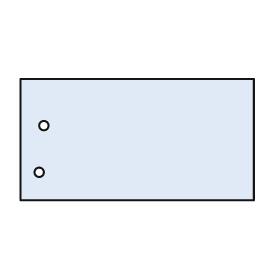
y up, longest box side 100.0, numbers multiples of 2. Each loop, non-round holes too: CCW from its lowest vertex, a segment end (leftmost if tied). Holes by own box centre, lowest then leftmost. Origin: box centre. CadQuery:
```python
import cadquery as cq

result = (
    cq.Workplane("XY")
    .moveTo(-50.0, -26.0)
    .lineTo(50.0, -26.0)
    .lineTo(50.0, 26.0)
    .lineTo(-50.0, 26.0)
    .close()
    .moveTo(-42.0, -14.0)
    .circle(2.0)
    .moveTo(-40.0, 6.0)
    .circle(2.0)
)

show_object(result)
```